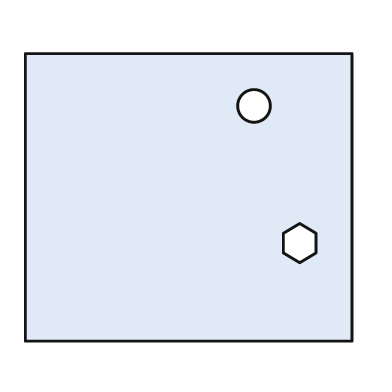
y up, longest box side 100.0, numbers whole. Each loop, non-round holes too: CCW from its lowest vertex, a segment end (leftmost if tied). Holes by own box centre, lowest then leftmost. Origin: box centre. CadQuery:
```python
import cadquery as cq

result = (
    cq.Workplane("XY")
    .moveTo(-50.0, -44.0)
    .lineTo(50.0, -44.0)
    .lineTo(50.0, 44.0)
    .lineTo(-50.0, 44.0)
    .close()
    .moveTo(34.0, -20.0)
    .lineTo(39.0, -17.0)
    .lineTo(39.0, -11.0)
    .lineTo(34.0, -8.0)
    .lineTo(29.0, -11.0)
    .lineTo(29.0, -17.0)
    .close()
    .moveTo(20.0, 28.0)
    .circle(5.0)
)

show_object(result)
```